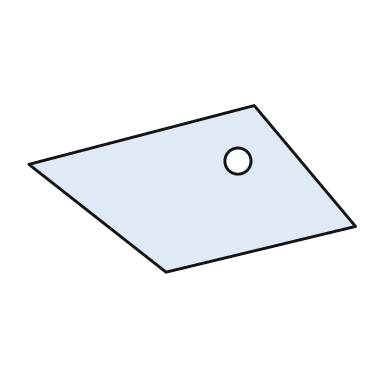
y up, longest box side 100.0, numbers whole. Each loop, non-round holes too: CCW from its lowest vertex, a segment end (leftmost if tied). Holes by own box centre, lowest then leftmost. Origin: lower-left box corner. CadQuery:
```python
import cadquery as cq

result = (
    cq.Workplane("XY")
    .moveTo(42.0, 0.0)
    .lineTo(100.0, 14.0)
    .lineTo(69.0, 51.0)
    .lineTo(0.0, 33.0)
    .close()
    .moveTo(64.0, 34.0)
    .circle(4.0)
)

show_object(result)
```